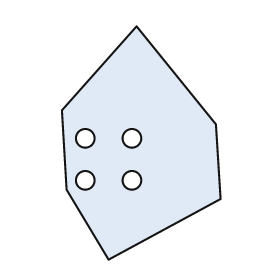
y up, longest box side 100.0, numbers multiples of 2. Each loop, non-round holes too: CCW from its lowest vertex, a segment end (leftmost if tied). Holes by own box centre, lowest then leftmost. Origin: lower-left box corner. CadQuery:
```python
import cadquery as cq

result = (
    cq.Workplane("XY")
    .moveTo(20.0, 0.0)
    .lineTo(68.0, 26.0)
    .lineTo(66.0, 58.0)
    .lineTo(32.0, 100.0)
    .lineTo(0.0, 64.0)
    .lineTo(2.0, 30.0)
    .close()
    .moveTo(10.0, 34.0)
    .circle(4.0)
    .moveTo(30.0, 34.0)
    .circle(4.0)
    .moveTo(10.0, 52.0)
    .circle(4.0)
    .moveTo(30.0, 52.0)
    .circle(4.0)
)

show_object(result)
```